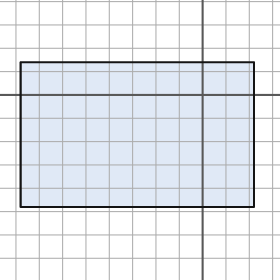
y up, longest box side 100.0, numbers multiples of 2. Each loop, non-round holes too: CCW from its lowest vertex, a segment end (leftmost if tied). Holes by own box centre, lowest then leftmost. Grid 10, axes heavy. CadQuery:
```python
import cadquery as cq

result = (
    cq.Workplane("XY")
    .moveTo(-78.0, -48.0)
    .lineTo(22.0, -48.0)
    .lineTo(22.0, 14.0)
    .lineTo(-78.0, 14.0)
    .close()
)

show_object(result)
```